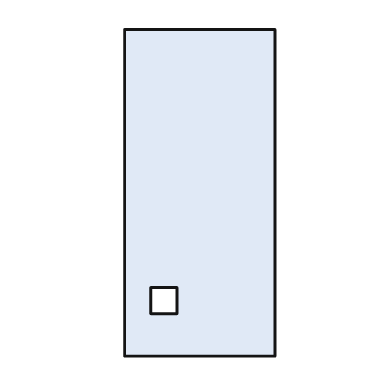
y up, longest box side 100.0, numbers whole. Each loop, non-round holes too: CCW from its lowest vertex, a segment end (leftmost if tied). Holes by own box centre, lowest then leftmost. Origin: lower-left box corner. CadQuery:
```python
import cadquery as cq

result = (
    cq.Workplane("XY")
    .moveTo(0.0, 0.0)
    .lineTo(46.0, 0.0)
    .lineTo(46.0, 100.0)
    .lineTo(0.0, 100.0)
    .close()
    .moveTo(8.0, 13.0)
    .lineTo(16.0, 13.0)
    .lineTo(16.0, 21.0)
    .lineTo(8.0, 21.0)
    .close()
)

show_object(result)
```